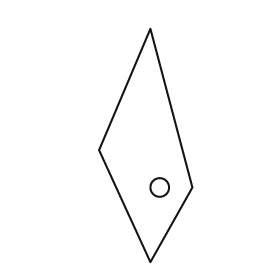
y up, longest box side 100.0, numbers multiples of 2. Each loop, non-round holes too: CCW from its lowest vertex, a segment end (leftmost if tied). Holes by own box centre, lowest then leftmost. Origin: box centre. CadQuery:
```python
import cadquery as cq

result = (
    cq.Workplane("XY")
    .moveTo(2.0, -50.0)
    .lineTo(20.0, -18.0)
    .lineTo(2.0, 50.0)
    .lineTo(-20.0, -2.0)
    .close()
    .moveTo(6.0, -18.0)
    .circle(4.0)
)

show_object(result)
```